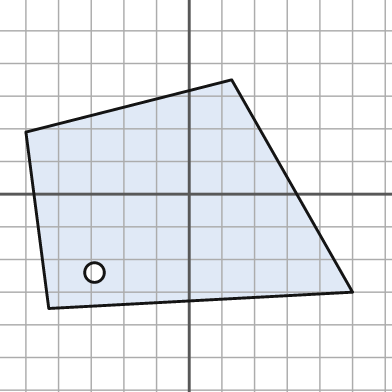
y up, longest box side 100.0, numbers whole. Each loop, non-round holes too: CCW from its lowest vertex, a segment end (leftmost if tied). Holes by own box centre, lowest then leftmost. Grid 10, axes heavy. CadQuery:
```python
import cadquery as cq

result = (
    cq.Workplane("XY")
    .moveTo(-43.0, -35.0)
    .lineTo(50.0, -30.0)
    .lineTo(13.0, 35.0)
    .lineTo(-50.0, 19.0)
    .close()
    .moveTo(-29.0, -24.0)
    .circle(3.0)
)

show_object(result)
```